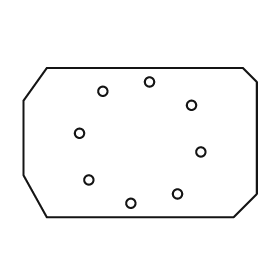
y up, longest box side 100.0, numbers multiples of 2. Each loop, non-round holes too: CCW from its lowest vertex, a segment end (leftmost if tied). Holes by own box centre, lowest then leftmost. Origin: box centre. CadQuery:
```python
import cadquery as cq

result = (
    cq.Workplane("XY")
    .moveTo(-40.0, -32.0)
    .lineTo(40.0, -32.0)
    .lineTo(50.0, -22.0)
    .lineTo(50.0, 26.0)
    .lineTo(44.0, 32.0)
    .lineTo(-40.0, 32.0)
    .lineTo(-50.0, 18.0)
    .lineTo(-50.0, -14.0)
    .close()
    .moveTo(-4.0, -26.0)
    .circle(2.0)
    .moveTo(16.0, -22.0)
    .circle(2.0)
    .moveTo(-22.0, -16.0)
    .circle(2.0)
    .moveTo(26.0, -4.0)
    .circle(2.0)
    .moveTo(-26.0, 4.0)
    .circle(2.0)
    .moveTo(22.0, 16.0)
    .circle(2.0)
    .moveTo(-16.0, 22.0)
    .circle(2.0)
    .moveTo(4.0, 26.0)
    .circle(2.0)
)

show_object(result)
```